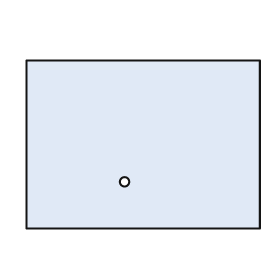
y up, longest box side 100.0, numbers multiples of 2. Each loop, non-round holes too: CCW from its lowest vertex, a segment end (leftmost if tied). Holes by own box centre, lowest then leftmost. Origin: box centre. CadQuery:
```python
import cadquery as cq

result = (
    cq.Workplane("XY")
    .moveTo(-50.0, -36.0)
    .lineTo(50.0, -36.0)
    .lineTo(50.0, 36.0)
    .lineTo(-50.0, 36.0)
    .close()
    .moveTo(-8.0, -16.0)
    .circle(2.0)
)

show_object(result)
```